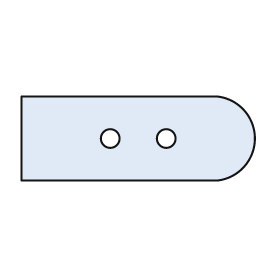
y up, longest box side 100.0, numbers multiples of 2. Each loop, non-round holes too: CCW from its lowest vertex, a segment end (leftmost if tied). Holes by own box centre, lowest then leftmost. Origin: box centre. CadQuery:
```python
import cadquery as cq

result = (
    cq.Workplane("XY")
    .moveTo(-50.0, -18.0)
    .lineTo(34.0, -18.0)
    .threePointArc((50.0, 0.0), (34.0, 18.0))
    .lineTo(-50.0, 18.0)
    .close()
    .moveTo(-12.0, 0.0)
    .circle(4.0)
    .moveTo(12.0, 0.0)
    .circle(4.0)
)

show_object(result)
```